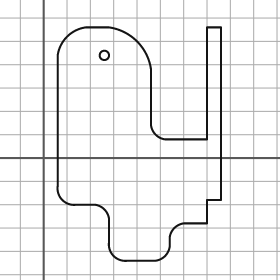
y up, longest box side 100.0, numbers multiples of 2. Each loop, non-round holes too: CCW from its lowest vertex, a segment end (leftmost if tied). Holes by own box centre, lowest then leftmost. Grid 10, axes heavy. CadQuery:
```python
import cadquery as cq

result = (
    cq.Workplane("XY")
    .moveTo(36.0, -44.0)
    .lineTo(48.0, -44.0)
    .threePointArc((52.0, -42.0), (54.0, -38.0))
    .lineTo(54.0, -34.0)
    .threePointArc((56.0, -30.0), (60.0, -28.0))
    .lineTo(70.0, -28.0)
    .lineTo(70.0, -18.0)
    .lineTo(76.0, -18.0)
    .lineTo(76.0, 56.0)
    .lineTo(70.0, 56.0)
    .lineTo(70.0, 8.0)
    .lineTo(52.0, 8.0)
    .threePointArc((48.0, 10.0), (46.0, 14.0))
    .lineTo(46.0, 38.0)
    .threePointArc((40.0, 50.0), (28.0, 56.0))
    .lineTo(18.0, 56.0)
    .threePointArc((10.0, 52.0), (6.0, 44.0))
    .lineTo(6.0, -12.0)
    .threePointArc((8.0, -18.0), (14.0, -20.0))
    .lineTo(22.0, -20.0)
    .threePointArc((26.0, -22.0), (28.0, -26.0))
    .lineTo(28.0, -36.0)
    .threePointArc((30.0, -42.0), (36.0, -44.0))
    .close()
    .moveTo(26.0, 44.0)
    .circle(2.0)
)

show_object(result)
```